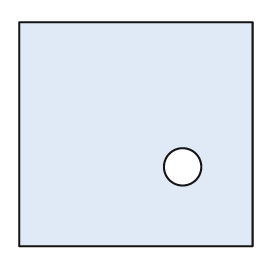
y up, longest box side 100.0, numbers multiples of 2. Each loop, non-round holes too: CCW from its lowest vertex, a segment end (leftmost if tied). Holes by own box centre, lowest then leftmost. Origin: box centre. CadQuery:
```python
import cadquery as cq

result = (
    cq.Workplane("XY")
    .moveTo(-50.0, -48.0)
    .lineTo(50.0, -48.0)
    .lineTo(50.0, 48.0)
    .lineTo(-50.0, 48.0)
    .close()
    .moveTo(20.0, -14.0)
    .circle(8.0)
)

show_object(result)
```